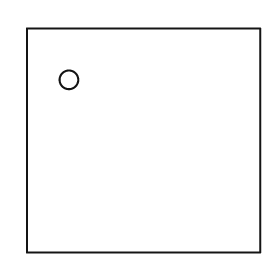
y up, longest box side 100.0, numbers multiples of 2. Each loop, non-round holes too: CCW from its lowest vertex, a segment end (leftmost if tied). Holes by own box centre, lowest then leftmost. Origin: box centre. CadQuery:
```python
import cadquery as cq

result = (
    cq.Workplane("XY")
    .moveTo(-50.0, -48.0)
    .lineTo(50.0, -48.0)
    .lineTo(50.0, 48.0)
    .lineTo(-50.0, 48.0)
    .close()
    .moveTo(-32.0, 26.0)
    .circle(4.0)
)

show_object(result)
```